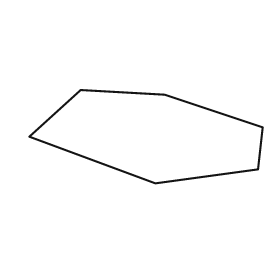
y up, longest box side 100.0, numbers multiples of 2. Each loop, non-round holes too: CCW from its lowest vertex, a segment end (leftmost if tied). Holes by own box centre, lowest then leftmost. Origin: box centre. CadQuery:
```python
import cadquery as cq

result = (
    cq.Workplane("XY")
    .moveTo(4.0, -20.0)
    .lineTo(48.0, -14.0)
    .lineTo(50.0, 4.0)
    .lineTo(8.0, 18.0)
    .lineTo(-28.0, 20.0)
    .lineTo(-50.0, 0.0)
    .close()
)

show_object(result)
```